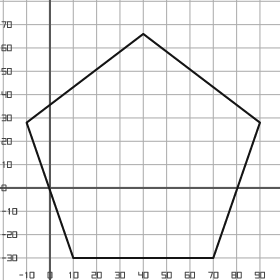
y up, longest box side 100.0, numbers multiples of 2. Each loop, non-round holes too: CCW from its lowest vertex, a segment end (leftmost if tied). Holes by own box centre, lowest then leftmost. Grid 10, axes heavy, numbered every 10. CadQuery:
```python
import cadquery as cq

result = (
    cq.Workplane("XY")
    .moveTo(10.0, -30.0)
    .lineTo(70.0, -30.0)
    .lineTo(90.0, 28.0)
    .lineTo(40.0, 66.0)
    .lineTo(-10.0, 28.0)
    .close()
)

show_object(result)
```